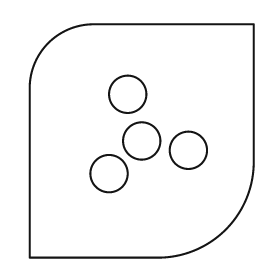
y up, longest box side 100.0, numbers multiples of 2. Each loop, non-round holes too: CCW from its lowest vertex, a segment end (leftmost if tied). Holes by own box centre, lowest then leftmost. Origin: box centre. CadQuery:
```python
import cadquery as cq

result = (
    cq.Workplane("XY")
    .moveTo(-48.0, -50.0)
    .lineTo(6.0, -50.0)
    .threePointArc((36.0, -38.0), (48.0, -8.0))
    .lineTo(48.0, 50.0)
    .lineTo(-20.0, 50.0)
    .threePointArc((-40.0, 42.0), (-48.0, 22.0))
    .close()
    .moveTo(-14.0, -14.0)
    .circle(8.0)
    .moveTo(20.0, -4.0)
    .circle(8.0)
    .moveTo(0.0, 0.0)
    .circle(8.0)
    .moveTo(-6.0, 20.0)
    .circle(8.0)
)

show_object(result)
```